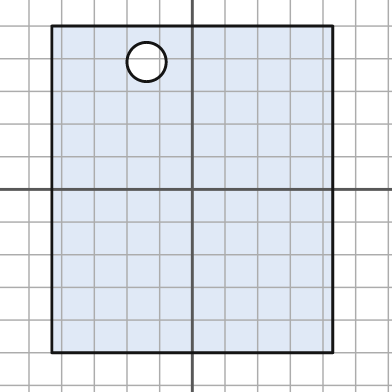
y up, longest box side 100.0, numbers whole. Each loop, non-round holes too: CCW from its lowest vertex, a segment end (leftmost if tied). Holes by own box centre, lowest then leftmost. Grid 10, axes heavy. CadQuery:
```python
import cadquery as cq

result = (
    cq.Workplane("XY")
    .moveTo(-43.0, -50.0)
    .lineTo(43.0, -50.0)
    .lineTo(43.0, 50.0)
    .lineTo(-43.0, 50.0)
    .close()
    .moveTo(-14.0, 39.0)
    .circle(6.0)
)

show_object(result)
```